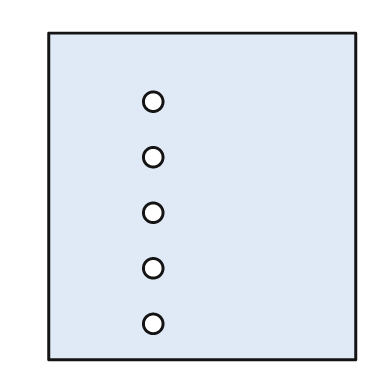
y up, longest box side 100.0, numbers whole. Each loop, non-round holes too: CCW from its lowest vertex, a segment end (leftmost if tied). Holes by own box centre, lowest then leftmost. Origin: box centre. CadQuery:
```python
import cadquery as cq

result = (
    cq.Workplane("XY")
    .moveTo(-47.0, -50.0)
    .lineTo(47.0, -50.0)
    .lineTo(47.0, 50.0)
    .lineTo(-47.0, 50.0)
    .close()
    .moveTo(-15.0, -39.0)
    .circle(3.0)
    .moveTo(-15.0, -22.0)
    .circle(3.0)
    .moveTo(-15.0, -5.0)
    .circle(3.0)
    .moveTo(-15.0, 12.0)
    .circle(3.0)
    .moveTo(-15.0, 29.0)
    .circle(3.0)
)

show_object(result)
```